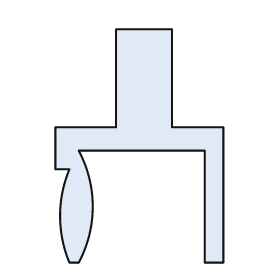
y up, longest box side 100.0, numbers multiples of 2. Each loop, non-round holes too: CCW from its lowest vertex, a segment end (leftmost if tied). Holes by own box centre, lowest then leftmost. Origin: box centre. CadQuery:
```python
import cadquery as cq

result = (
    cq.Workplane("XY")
    .moveTo(-30.0, -50.0)
    .lineTo(-26.0, -50.0)
    .threePointArc((-20.0, -26.0), (-26.0, -2.0))
    .lineTo(28.0, -2.0)
    .lineTo(28.0, -50.0)
    .lineTo(36.0, -50.0)
    .lineTo(36.0, 8.0)
    .lineTo(14.0, 8.0)
    .lineTo(14.0, 50.0)
    .lineTo(-10.0, 50.0)
    .lineTo(-10.0, 8.0)
    .lineTo(-36.0, 8.0)
    .lineTo(-36.0, -10.0)
    .lineTo(-30.0, -10.0)
    .threePointArc((-34.0, -30.0), (-30.0, -50.0))
    .close()
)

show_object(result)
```